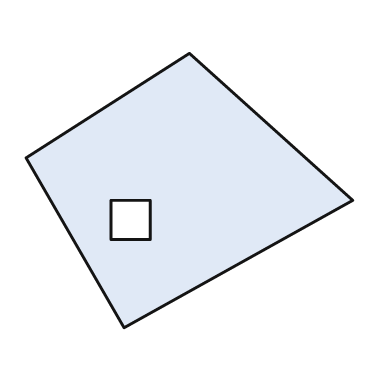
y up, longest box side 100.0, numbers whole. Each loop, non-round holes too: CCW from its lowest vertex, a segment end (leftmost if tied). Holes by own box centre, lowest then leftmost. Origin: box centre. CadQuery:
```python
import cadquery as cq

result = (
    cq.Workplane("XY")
    .moveTo(-20.0, -42.0)
    .lineTo(50.0, -3.0)
    .lineTo(0.0, 42.0)
    .lineTo(-50.0, 10.0)
    .close()
    .moveTo(-24.0, -15.0)
    .lineTo(-12.0, -15.0)
    .lineTo(-12.0, -3.0)
    .lineTo(-24.0, -3.0)
    .close()
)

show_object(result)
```